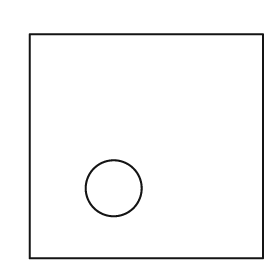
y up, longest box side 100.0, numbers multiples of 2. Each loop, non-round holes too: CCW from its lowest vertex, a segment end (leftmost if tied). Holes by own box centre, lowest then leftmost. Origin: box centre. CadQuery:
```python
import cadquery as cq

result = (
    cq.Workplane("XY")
    .moveTo(-50.0, -48.0)
    .lineTo(50.0, -48.0)
    .lineTo(50.0, 48.0)
    .lineTo(-50.0, 48.0)
    .close()
    .moveTo(-14.0, -18.0)
    .circle(12.0)
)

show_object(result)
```